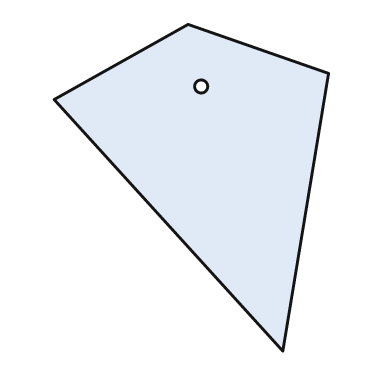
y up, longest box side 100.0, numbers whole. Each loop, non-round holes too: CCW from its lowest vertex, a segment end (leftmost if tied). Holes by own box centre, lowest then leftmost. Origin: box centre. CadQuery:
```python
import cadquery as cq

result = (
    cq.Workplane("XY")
    .moveTo(28.0, -50.0)
    .lineTo(42.0, 35.0)
    .lineTo(-1.0, 50.0)
    .lineTo(-42.0, 27.0)
    .close()
    .moveTo(3.0, 31.0)
    .circle(2.0)
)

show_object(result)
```